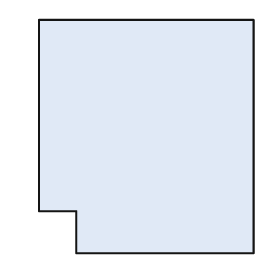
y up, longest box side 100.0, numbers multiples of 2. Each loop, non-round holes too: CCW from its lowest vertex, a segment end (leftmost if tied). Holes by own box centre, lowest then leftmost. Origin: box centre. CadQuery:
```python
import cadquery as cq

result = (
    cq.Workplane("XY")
    .moveTo(-30.0, -50.0)
    .lineTo(46.0, -50.0)
    .lineTo(46.0, 50.0)
    .lineTo(-46.0, 50.0)
    .lineTo(-46.0, -32.0)
    .lineTo(-30.0, -32.0)
    .close()
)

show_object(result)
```